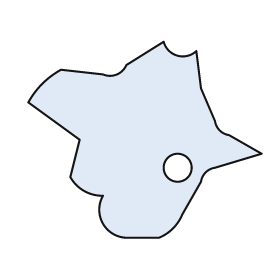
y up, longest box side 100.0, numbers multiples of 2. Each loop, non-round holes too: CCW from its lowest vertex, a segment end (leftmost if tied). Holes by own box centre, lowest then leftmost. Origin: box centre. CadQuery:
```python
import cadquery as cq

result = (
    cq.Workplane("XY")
    .moveTo(-8.0, -42.0)
    .lineTo(6.0, -42.0)
    .threePointArc((12.0, -38.0), (16.0, -32.0))
    .lineTo(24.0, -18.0)
    .threePointArc((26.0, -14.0), (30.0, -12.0))
    .lineTo(50.0, -6.0)
    .lineTo(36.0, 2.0)
    .threePointArc((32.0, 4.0), (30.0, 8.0))
    .lineTo(24.0, 22.0)
    .lineTo(22.0, 38.0)
    .threePointArc((14.0, 36.0), (8.0, 42.0))
    .lineTo(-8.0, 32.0)
    .threePointArc((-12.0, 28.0), (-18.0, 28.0))
    .lineTo(-36.0, 30.0)
    .threePointArc((-44.0, 24.0), (-50.0, 16.0))
    .lineTo(-28.0, 0.0)
    .lineTo(-32.0, -16.0)
    .threePointArc((-26.0, -22.0), (-18.0, -24.0))
    .threePointArc((-18.0, -36.0), (-8.0, -42.0))
    .close()
    .moveTo(14.0, -12.0)
    .circle(6.0)
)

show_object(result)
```